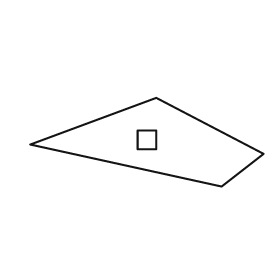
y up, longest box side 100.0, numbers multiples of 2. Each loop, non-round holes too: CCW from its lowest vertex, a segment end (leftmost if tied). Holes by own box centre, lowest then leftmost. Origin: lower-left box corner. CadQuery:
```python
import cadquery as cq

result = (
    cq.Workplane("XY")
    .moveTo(82.0, 0.0)
    .lineTo(100.0, 14.0)
    .lineTo(54.0, 38.0)
    .lineTo(0.0, 18.0)
    .close()
    .moveTo(46.0, 16.0)
    .lineTo(54.0, 16.0)
    .lineTo(54.0, 24.0)
    .lineTo(46.0, 24.0)
    .close()
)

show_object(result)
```